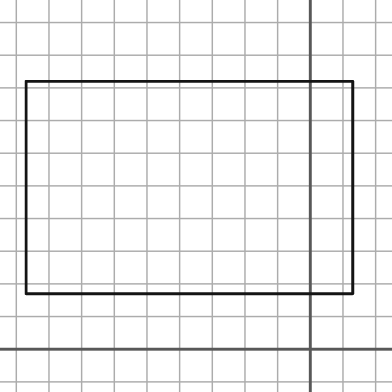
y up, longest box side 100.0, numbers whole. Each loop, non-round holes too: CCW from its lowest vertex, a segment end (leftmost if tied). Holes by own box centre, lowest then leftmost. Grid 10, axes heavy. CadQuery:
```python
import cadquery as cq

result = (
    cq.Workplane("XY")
    .moveTo(-87.0, 17.0)
    .lineTo(13.0, 17.0)
    .lineTo(13.0, 82.0)
    .lineTo(-87.0, 82.0)
    .close()
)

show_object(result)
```